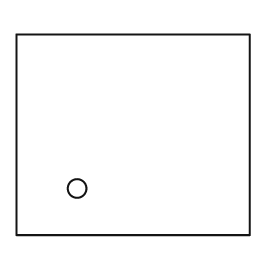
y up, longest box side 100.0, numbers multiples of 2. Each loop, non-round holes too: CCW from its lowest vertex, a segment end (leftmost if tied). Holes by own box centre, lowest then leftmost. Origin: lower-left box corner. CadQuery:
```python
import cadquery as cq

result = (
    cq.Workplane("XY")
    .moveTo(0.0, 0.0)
    .lineTo(100.0, 0.0)
    .lineTo(100.0, 86.0)
    .lineTo(0.0, 86.0)
    .close()
    .moveTo(26.0, 20.0)
    .circle(4.0)
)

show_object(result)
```